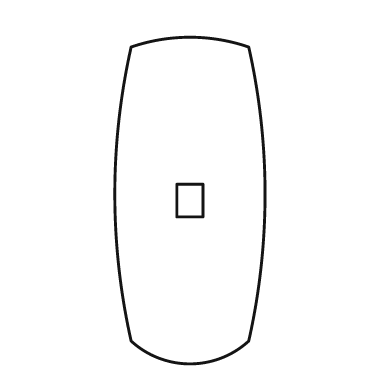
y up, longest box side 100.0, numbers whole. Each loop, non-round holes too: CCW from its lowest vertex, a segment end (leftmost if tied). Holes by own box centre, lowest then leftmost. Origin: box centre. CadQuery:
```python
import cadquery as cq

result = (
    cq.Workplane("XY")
    .moveTo(-18.0, -43.0)
    .threePointArc((0.0, -50.0), (18.0, -43.0))
    .threePointArc((23.0, 2.0), (18.0, 47.0))
    .threePointArc((0.0, 50.0), (-18.0, 47.0))
    .threePointArc((-23.0, 2.0), (-18.0, -43.0))
    .close()
    .moveTo(-4.0, -5.0)
    .lineTo(4.0, -5.0)
    .lineTo(4.0, 5.0)
    .lineTo(-4.0, 5.0)
    .close()
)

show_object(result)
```